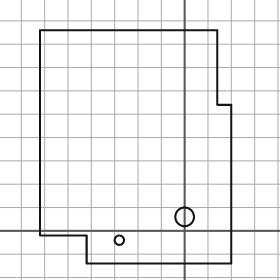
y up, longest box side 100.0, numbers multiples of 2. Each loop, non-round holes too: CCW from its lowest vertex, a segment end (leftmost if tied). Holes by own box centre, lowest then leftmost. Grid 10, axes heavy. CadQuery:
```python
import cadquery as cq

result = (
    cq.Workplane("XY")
    .moveTo(-42.0, -14.0)
    .lineTo(20.0, -14.0)
    .lineTo(20.0, 54.0)
    .lineTo(14.0, 54.0)
    .lineTo(14.0, 86.0)
    .lineTo(-62.0, 86.0)
    .lineTo(-62.0, -2.0)
    .lineTo(-42.0, -2.0)
    .close()
    .moveTo(-28.0, -4.0)
    .circle(2.0)
    .moveTo(0.0, 6.0)
    .circle(4.0)
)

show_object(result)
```